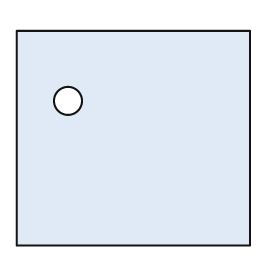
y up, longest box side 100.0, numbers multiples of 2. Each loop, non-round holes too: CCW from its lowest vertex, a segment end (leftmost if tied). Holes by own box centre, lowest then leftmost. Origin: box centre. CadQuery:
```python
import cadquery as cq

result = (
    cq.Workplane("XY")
    .moveTo(-50.0, -46.0)
    .lineTo(50.0, -46.0)
    .lineTo(50.0, 46.0)
    .lineTo(-50.0, 46.0)
    .close()
    .moveTo(-28.0, 16.0)
    .circle(6.0)
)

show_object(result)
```